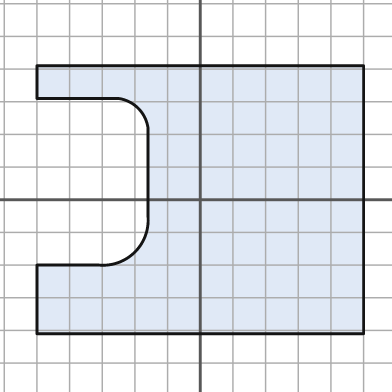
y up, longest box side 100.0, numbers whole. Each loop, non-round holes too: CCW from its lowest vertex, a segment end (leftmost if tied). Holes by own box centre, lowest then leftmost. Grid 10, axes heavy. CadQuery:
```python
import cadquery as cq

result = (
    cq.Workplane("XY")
    .moveTo(-50.0, -41.0)
    .lineTo(50.0, -41.0)
    .lineTo(50.0, 41.0)
    .lineTo(-50.0, 41.0)
    .lineTo(-50.0, 31.0)
    .lineTo(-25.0, 31.0)
    .threePointArc((-19.0, 28.0), (-16.0, 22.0))
    .lineTo(-16.0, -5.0)
    .threePointArc((-20.0, -16.0), (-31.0, -20.0))
    .lineTo(-50.0, -20.0)
    .close()
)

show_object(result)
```